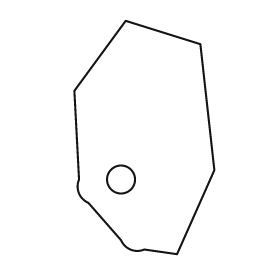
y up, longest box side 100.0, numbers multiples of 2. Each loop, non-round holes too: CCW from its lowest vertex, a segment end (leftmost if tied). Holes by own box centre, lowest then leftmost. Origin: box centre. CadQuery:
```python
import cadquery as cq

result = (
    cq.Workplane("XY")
    .moveTo(14.0, -50.0)
    .lineTo(30.0, -14.0)
    .lineTo(24.0, 40.0)
    .lineTo(-8.0, 50.0)
    .lineTo(-30.0, 20.0)
    .lineTo(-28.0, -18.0)
    .threePointArc((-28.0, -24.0), (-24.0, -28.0))
    .lineTo(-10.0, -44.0)
    .threePointArc((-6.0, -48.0), (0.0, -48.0))
    .close()
    .moveTo(-10.0, -18.0)
    .circle(6.0)
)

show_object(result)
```